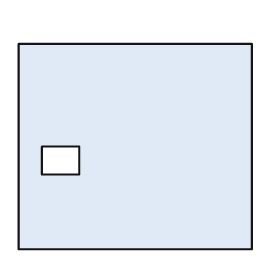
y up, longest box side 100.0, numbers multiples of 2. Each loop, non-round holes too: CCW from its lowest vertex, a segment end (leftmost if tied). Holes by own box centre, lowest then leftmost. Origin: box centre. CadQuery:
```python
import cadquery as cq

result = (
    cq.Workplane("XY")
    .moveTo(-50.0, -44.0)
    .lineTo(50.0, -44.0)
    .lineTo(50.0, 44.0)
    .lineTo(-50.0, 44.0)
    .close()
    .moveTo(-40.0, -12.0)
    .lineTo(-24.0, -12.0)
    .lineTo(-24.0, 0.0)
    .lineTo(-40.0, 0.0)
    .close()
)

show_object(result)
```